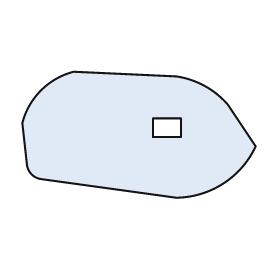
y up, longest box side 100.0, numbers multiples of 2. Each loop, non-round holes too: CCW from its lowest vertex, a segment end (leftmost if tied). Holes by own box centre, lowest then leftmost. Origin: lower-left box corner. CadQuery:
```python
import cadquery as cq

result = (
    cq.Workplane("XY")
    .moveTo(66.0, 0.0)
    .threePointArc((86.0, 6.0), (100.0, 22.0))
    .lineTo(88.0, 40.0)
    .threePointArc((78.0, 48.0), (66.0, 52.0))
    .lineTo(22.0, 54.0)
    .threePointArc((8.0, 46.0), (0.0, 32.0))
    .lineTo(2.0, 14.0)
    .threePointArc((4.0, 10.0), (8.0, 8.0))
    .close()
    .moveTo(56.0, 26.0)
    .lineTo(68.0, 26.0)
    .lineTo(68.0, 34.0)
    .lineTo(56.0, 34.0)
    .close()
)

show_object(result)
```